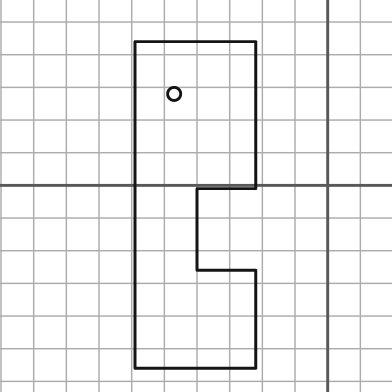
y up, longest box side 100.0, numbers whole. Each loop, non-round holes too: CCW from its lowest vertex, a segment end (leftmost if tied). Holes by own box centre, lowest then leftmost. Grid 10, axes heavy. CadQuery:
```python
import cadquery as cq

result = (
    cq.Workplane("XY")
    .moveTo(-59.0, -56.0)
    .lineTo(-22.0, -56.0)
    .lineTo(-22.0, -26.0)
    .lineTo(-40.0, -26.0)
    .lineTo(-40.0, -1.0)
    .lineTo(-22.0, -1.0)
    .lineTo(-22.0, 44.0)
    .lineTo(-59.0, 44.0)
    .close()
    .moveTo(-47.0, 28.0)
    .circle(2.0)
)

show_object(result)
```